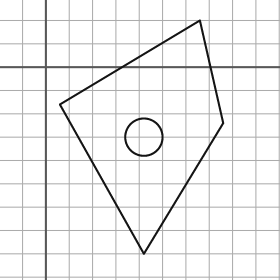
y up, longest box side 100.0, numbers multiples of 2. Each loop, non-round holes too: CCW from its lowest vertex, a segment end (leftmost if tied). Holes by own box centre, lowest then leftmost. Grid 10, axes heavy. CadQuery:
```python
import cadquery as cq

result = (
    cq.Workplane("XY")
    .moveTo(42.0, -80.0)
    .lineTo(76.0, -24.0)
    .lineTo(66.0, 20.0)
    .lineTo(6.0, -16.0)
    .close()
    .moveTo(42.0, -30.0)
    .circle(8.0)
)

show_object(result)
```